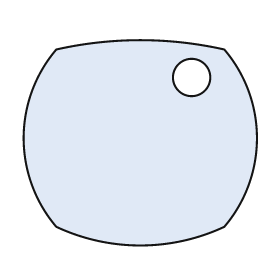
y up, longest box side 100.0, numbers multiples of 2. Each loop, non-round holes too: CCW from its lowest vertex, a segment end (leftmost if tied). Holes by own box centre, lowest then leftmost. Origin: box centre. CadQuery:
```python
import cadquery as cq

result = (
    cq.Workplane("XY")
    .moveTo(-36.0, -36.0)
    .threePointArc((0.0, -44.0), (36.0, -36.0))
    .threePointArc((50.0, 2.0), (36.0, 40.0))
    .threePointArc((0.0, 44.0), (-36.0, 40.0))
    .threePointArc((-50.0, 2.0), (-36.0, -36.0))
    .close()
    .moveTo(22.0, 28.0)
    .circle(8.0)
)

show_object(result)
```